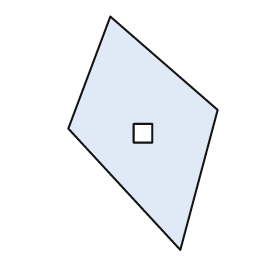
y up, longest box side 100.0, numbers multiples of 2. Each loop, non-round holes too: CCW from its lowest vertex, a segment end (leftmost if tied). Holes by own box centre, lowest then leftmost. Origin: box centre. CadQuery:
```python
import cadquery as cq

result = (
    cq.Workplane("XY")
    .moveTo(16.0, -50.0)
    .lineTo(32.0, 10.0)
    .lineTo(-14.0, 50.0)
    .lineTo(-32.0, 2.0)
    .close()
    .moveTo(-4.0, -4.0)
    .lineTo(4.0, -4.0)
    .lineTo(4.0, 4.0)
    .lineTo(-4.0, 4.0)
    .close()
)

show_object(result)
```